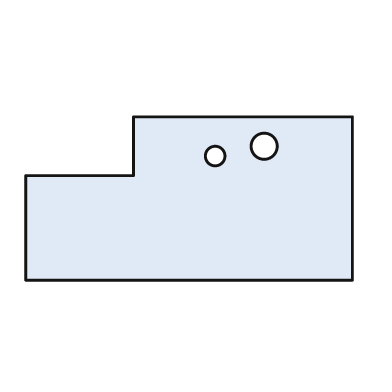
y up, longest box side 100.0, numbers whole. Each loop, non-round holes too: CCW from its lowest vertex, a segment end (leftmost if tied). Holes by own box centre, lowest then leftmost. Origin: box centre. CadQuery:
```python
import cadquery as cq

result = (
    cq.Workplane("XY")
    .moveTo(-50.0, -25.0)
    .lineTo(50.0, -25.0)
    .lineTo(50.0, 25.0)
    .lineTo(-17.0, 25.0)
    .lineTo(-17.0, 7.0)
    .lineTo(-50.0, 7.0)
    .close()
    .moveTo(8.0, 13.0)
    .circle(3.0)
    .moveTo(23.0, 16.0)
    .circle(4.0)
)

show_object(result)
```